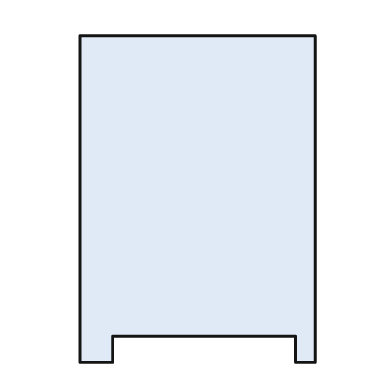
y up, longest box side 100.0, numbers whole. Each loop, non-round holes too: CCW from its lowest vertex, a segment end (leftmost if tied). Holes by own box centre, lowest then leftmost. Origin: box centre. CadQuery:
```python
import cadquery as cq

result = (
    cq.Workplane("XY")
    .moveTo(-36.0, -50.0)
    .lineTo(-26.0, -50.0)
    .lineTo(-26.0, -42.0)
    .lineTo(30.0, -42.0)
    .lineTo(30.0, -50.0)
    .lineTo(36.0, -50.0)
    .lineTo(36.0, 50.0)
    .lineTo(-36.0, 50.0)
    .close()
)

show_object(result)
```